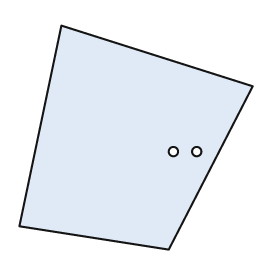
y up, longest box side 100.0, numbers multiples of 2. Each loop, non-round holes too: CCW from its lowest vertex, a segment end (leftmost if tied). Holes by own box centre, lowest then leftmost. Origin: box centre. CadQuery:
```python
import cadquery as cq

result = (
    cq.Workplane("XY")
    .moveTo(14.0, -48.0)
    .lineTo(50.0, 22.0)
    .lineTo(-32.0, 48.0)
    .lineTo(-50.0, -38.0)
    .close()
    .moveTo(16.0, -6.0)
    .circle(2.0)
    .moveTo(26.0, -6.0)
    .circle(2.0)
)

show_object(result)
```